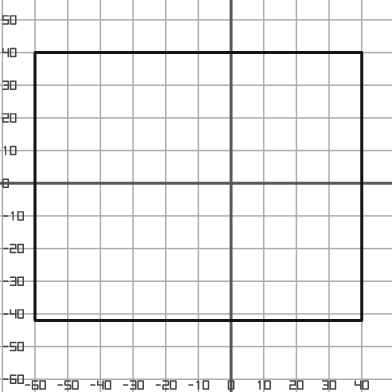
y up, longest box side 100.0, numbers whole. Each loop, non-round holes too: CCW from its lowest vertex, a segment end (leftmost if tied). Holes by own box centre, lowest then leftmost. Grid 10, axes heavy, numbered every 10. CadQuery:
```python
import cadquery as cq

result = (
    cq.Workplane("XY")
    .moveTo(-60.0, -42.0)
    .lineTo(40.0, -42.0)
    .lineTo(40.0, 40.0)
    .lineTo(-60.0, 40.0)
    .close()
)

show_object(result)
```